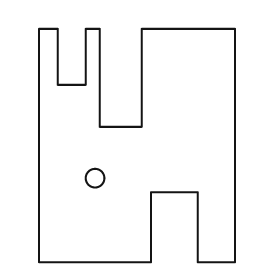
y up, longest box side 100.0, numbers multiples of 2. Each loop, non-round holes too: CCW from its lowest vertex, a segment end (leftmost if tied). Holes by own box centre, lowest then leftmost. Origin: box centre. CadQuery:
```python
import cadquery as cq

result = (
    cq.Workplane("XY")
    .moveTo(-42.0, -50.0)
    .lineTo(6.0, -50.0)
    .lineTo(6.0, -20.0)
    .lineTo(26.0, -20.0)
    .lineTo(26.0, -50.0)
    .lineTo(42.0, -50.0)
    .lineTo(42.0, 50.0)
    .lineTo(2.0, 50.0)
    .lineTo(2.0, 8.0)
    .lineTo(-16.0, 8.0)
    .lineTo(-16.0, 50.0)
    .lineTo(-22.0, 50.0)
    .lineTo(-22.0, 26.0)
    .lineTo(-34.0, 26.0)
    .lineTo(-34.0, 50.0)
    .lineTo(-42.0, 50.0)
    .close()
    .moveTo(-18.0, -14.0)
    .circle(4.0)
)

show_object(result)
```